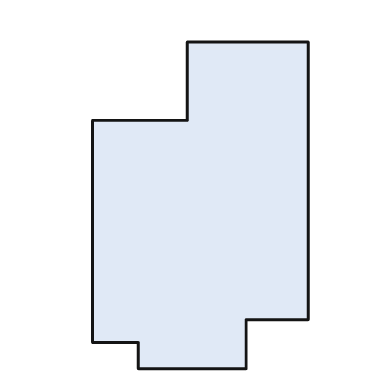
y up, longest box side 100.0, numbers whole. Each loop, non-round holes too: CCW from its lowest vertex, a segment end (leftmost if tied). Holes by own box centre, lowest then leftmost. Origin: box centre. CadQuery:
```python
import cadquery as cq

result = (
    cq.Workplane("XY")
    .moveTo(-19.0, -50.0)
    .lineTo(14.0, -50.0)
    .lineTo(14.0, -35.0)
    .lineTo(33.0, -35.0)
    .lineTo(33.0, 50.0)
    .lineTo(-4.0, 50.0)
    .lineTo(-4.0, 26.0)
    .lineTo(-33.0, 26.0)
    .lineTo(-33.0, -42.0)
    .lineTo(-19.0, -42.0)
    .close()
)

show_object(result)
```